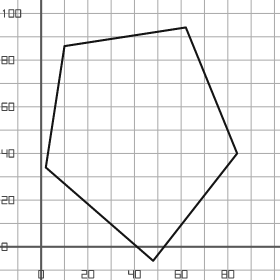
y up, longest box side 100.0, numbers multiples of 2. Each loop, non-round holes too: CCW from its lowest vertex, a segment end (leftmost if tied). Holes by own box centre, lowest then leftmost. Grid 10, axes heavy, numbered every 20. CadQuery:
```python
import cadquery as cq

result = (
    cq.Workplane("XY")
    .moveTo(48.0, -6.0)
    .lineTo(84.0, 40.0)
    .lineTo(62.0, 94.0)
    .lineTo(10.0, 86.0)
    .lineTo(2.0, 34.0)
    .close()
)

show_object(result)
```